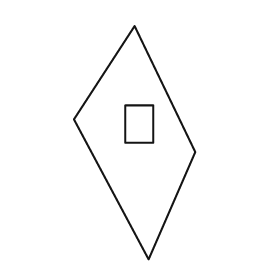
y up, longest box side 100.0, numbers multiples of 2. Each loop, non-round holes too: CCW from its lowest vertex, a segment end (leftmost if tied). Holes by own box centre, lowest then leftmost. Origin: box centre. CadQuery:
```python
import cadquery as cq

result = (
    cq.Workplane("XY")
    .moveTo(6.0, -50.0)
    .lineTo(26.0, -4.0)
    .lineTo(0.0, 50.0)
    .lineTo(-26.0, 10.0)
    .close()
    .moveTo(-4.0, 0.0)
    .lineTo(8.0, 0.0)
    .lineTo(8.0, 16.0)
    .lineTo(-4.0, 16.0)
    .close()
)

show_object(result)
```